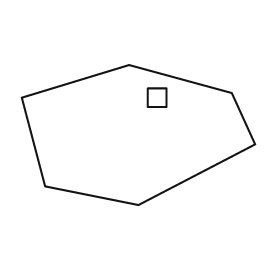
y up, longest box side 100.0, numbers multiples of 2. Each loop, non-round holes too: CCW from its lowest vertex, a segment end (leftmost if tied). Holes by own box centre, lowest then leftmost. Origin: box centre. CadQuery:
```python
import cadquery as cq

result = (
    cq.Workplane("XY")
    .moveTo(0.0, -30.0)
    .lineTo(50.0, -4.0)
    .lineTo(40.0, 18.0)
    .lineTo(-4.0, 30.0)
    .lineTo(-50.0, 16.0)
    .lineTo(-40.0, -22.0)
    .close()
    .moveTo(4.0, 12.0)
    .lineTo(12.0, 12.0)
    .lineTo(12.0, 20.0)
    .lineTo(4.0, 20.0)
    .close()
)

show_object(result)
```